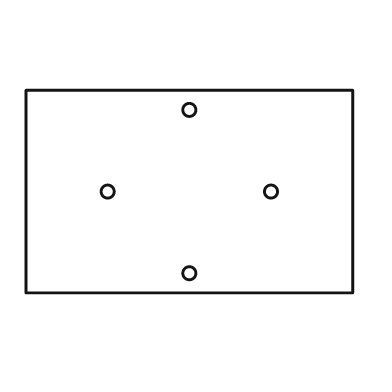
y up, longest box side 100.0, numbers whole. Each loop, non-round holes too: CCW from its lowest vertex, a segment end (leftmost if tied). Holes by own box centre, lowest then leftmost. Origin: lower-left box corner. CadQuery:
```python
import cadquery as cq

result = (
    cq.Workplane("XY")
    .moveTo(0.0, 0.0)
    .lineTo(100.0, 0.0)
    .lineTo(100.0, 62.0)
    .lineTo(0.0, 62.0)
    .close()
    .moveTo(50.0, 6.0)
    .circle(2.0)
    .moveTo(25.0, 31.0)
    .circle(2.0)
    .moveTo(75.0, 31.0)
    .circle(2.0)
    .moveTo(50.0, 56.0)
    .circle(2.0)
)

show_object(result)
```